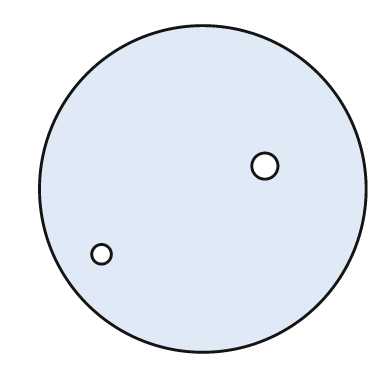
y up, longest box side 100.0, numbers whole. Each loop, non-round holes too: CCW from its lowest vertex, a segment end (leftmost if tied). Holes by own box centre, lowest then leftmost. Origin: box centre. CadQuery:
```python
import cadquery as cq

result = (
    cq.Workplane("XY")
    .moveTo(0.0, 0.0)
    .circle(50.0)
    .moveTo(-31.0, -20.0)
    .circle(3.0)
    .moveTo(19.0, 7.0)
    .circle(4.0)
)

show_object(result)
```